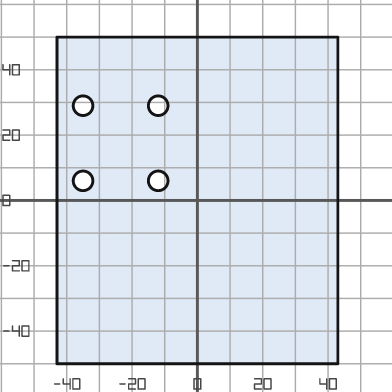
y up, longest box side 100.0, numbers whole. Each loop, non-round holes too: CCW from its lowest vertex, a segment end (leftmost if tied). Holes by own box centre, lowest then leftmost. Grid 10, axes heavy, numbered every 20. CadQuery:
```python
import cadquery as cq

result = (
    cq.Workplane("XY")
    .moveTo(-43.0, -50.0)
    .lineTo(43.0, -50.0)
    .lineTo(43.0, 50.0)
    .lineTo(-43.0, 50.0)
    .close()
    .moveTo(-35.0, 6.0)
    .circle(3.0)
    .moveTo(-12.0, 6.0)
    .circle(3.0)
    .moveTo(-35.0, 29.0)
    .circle(3.0)
    .moveTo(-12.0, 29.0)
    .circle(3.0)
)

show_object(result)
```